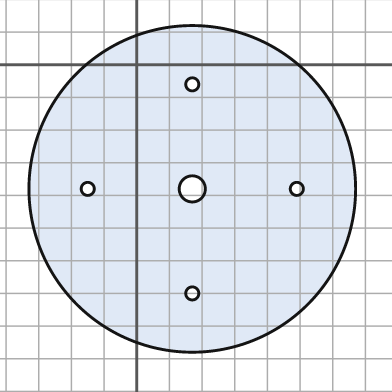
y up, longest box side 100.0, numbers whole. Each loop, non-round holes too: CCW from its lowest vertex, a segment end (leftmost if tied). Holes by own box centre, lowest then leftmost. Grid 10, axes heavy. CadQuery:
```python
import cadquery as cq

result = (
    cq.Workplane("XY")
    .moveTo(17.0, -38.0)
    .circle(50.0)
    .moveTo(17.0, -70.0)
    .circle(2.0)
    .moveTo(-15.0, -38.0)
    .circle(2.0)
    .moveTo(17.0, -38.0)
    .circle(4.0)
    .moveTo(49.0, -38.0)
    .circle(2.0)
    .moveTo(17.0, -6.0)
    .circle(2.0)
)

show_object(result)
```